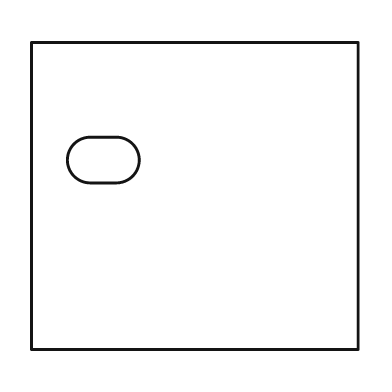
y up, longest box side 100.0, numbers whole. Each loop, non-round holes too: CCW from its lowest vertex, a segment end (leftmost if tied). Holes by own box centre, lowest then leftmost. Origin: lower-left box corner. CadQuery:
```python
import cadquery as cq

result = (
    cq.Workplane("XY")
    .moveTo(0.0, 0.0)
    .lineTo(100.0, 0.0)
    .lineTo(100.0, 94.0)
    .lineTo(0.0, 94.0)
    .close()
    .moveTo(18.0, 51.0)
    .lineTo(26.0, 51.0)
    .threePointArc((33.0, 58.0), (26.0, 65.0))
    .lineTo(18.0, 65.0)
    .threePointArc((11.0, 58.0), (18.0, 51.0))
    .close()
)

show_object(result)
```